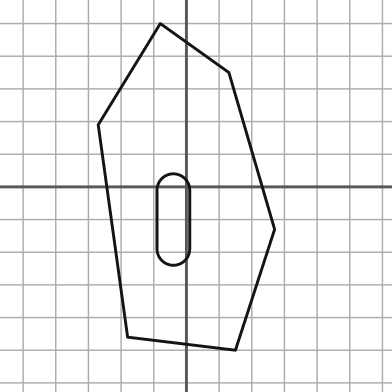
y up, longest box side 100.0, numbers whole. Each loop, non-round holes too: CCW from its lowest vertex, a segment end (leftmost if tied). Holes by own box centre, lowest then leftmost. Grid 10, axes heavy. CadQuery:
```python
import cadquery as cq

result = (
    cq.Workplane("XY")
    .moveTo(15.0, -50.0)
    .lineTo(27.0, -13.0)
    .lineTo(13.0, 35.0)
    .lineTo(-8.0, 50.0)
    .lineTo(-27.0, 19.0)
    .lineTo(-18.0, -46.0)
    .close()
    .moveTo(-9.0, -19.0)
    .threePointArc((-4.0, -24.0), (1.0, -19.0))
    .lineTo(1.0, -1.0)
    .threePointArc((-4.0, 4.0), (-9.0, -1.0))
    .close()
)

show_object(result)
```